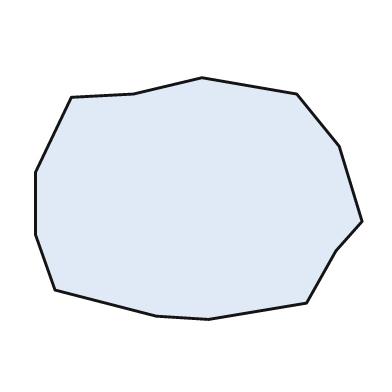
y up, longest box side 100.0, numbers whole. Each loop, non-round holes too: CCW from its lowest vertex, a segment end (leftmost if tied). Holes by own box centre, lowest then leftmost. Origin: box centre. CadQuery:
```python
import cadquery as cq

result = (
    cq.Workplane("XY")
    .moveTo(3.0, -37.0)
    .lineTo(33.0, -32.0)
    .lineTo(42.0, -16.0)
    .lineTo(50.0, -7.0)
    .lineTo(43.0, 16.0)
    .lineTo(30.0, 32.0)
    .lineTo(1.0, 37.0)
    .lineTo(-20.0, 32.0)
    .lineTo(-39.0, 31.0)
    .lineTo(-50.0, 8.0)
    .lineTo(-50.0, -11.0)
    .lineTo(-44.0, -28.0)
    .lineTo(-13.0, -36.0)
    .close()
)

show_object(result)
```